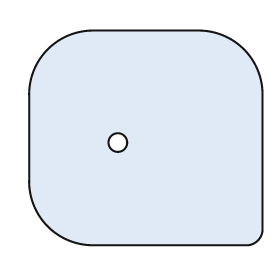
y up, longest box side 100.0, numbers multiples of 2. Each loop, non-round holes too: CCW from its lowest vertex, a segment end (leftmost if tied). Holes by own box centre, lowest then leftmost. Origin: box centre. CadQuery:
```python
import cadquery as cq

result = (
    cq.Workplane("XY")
    .moveTo(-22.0, -46.0)
    .lineTo(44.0, -46.0)
    .threePointArc((48.0, -44.0), (50.0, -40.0))
    .lineTo(50.0, 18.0)
    .threePointArc((42.0, 38.0), (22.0, 46.0))
    .lineTo(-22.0, 46.0)
    .threePointArc((-42.0, 38.0), (-50.0, 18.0))
    .lineTo(-50.0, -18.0)
    .threePointArc((-42.0, -38.0), (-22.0, -46.0))
    .close()
    .moveTo(-12.0, -2.0)
    .circle(4.0)
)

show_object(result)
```